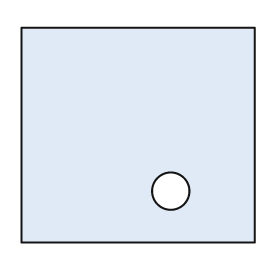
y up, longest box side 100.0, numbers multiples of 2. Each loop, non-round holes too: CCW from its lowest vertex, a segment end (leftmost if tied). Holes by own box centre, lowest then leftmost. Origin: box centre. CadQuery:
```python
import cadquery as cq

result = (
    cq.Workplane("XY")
    .moveTo(-50.0, -46.0)
    .lineTo(50.0, -46.0)
    .lineTo(50.0, 46.0)
    .lineTo(-50.0, 46.0)
    .close()
    .moveTo(14.0, -24.0)
    .circle(8.0)
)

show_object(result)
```